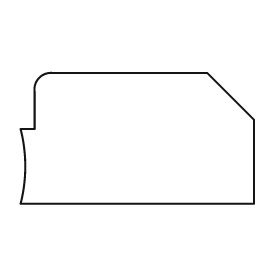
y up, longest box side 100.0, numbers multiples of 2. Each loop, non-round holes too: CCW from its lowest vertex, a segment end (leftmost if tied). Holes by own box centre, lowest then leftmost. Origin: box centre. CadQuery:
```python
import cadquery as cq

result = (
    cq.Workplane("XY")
    .moveTo(-50.0, -28.0)
    .lineTo(50.0, -28.0)
    .lineTo(50.0, 8.0)
    .lineTo(30.0, 28.0)
    .lineTo(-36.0, 28.0)
    .threePointArc((-42.0, 26.0), (-44.0, 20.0))
    .lineTo(-44.0, 4.0)
    .lineTo(-50.0, 4.0)
    .threePointArc((-48.0, -12.0), (-50.0, -28.0))
    .close()
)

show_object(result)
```